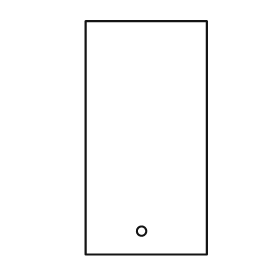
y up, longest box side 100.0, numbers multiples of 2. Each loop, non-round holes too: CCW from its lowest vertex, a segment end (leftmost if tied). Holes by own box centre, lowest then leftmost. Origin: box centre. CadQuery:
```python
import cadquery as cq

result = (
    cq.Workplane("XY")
    .moveTo(-26.0, -50.0)
    .lineTo(26.0, -50.0)
    .lineTo(26.0, 50.0)
    .lineTo(-26.0, 50.0)
    .close()
    .moveTo(-2.0, -40.0)
    .circle(2.0)
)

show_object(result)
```